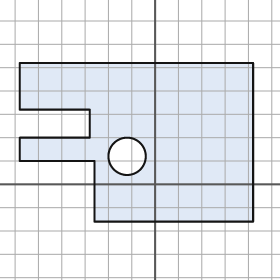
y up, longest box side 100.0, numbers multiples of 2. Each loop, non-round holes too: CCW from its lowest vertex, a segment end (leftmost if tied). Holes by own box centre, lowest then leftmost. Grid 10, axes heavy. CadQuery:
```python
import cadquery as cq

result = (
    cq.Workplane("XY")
    .moveTo(-26.0, -16.0)
    .lineTo(42.0, -16.0)
    .lineTo(42.0, 52.0)
    .lineTo(-58.0, 52.0)
    .lineTo(-58.0, 32.0)
    .lineTo(-28.0, 32.0)
    .lineTo(-28.0, 20.0)
    .lineTo(-58.0, 20.0)
    .lineTo(-58.0, 10.0)
    .lineTo(-26.0, 10.0)
    .close()
    .moveTo(-12.0, 12.0)
    .circle(8.0)
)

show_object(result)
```